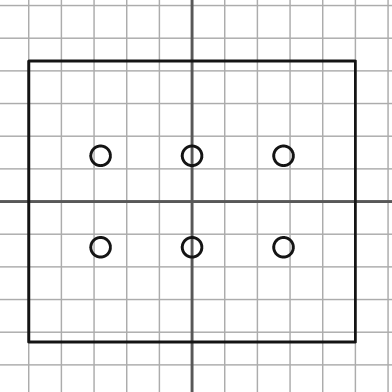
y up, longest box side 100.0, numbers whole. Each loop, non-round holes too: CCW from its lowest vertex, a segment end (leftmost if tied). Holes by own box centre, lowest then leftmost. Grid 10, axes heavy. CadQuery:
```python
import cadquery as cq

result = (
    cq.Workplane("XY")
    .moveTo(-50.0, -43.0)
    .lineTo(50.0, -43.0)
    .lineTo(50.0, 43.0)
    .lineTo(-50.0, 43.0)
    .close()
    .moveTo(-28.0, -14.0)
    .circle(3.0)
    .moveTo(0.0, -14.0)
    .circle(3.0)
    .moveTo(28.0, -14.0)
    .circle(3.0)
    .moveTo(-28.0, 14.0)
    .circle(3.0)
    .moveTo(0.0, 14.0)
    .circle(3.0)
    .moveTo(28.0, 14.0)
    .circle(3.0)
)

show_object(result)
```